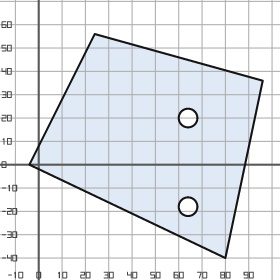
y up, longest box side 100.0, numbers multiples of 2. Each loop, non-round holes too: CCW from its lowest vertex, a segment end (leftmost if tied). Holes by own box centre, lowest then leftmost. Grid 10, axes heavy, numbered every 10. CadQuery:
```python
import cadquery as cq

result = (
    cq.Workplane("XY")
    .moveTo(80.0, -40.0)
    .lineTo(96.0, 36.0)
    .lineTo(24.0, 56.0)
    .lineTo(-4.0, 0.0)
    .close()
    .moveTo(64.0, -18.0)
    .circle(4.0)
    .moveTo(64.0, 20.0)
    .circle(4.0)
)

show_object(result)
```